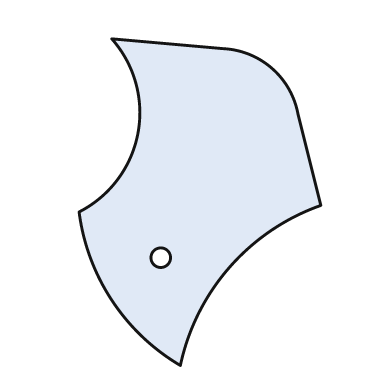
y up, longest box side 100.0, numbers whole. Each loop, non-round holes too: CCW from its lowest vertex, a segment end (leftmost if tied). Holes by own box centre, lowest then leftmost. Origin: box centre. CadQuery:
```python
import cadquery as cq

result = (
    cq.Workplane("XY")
    .moveTo(-6.0, -50.0)
    .threePointArc((9.0, -20.0), (37.0, -1.0))
    .lineTo(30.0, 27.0)
    .threePointArc((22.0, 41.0), (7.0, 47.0))
    .lineTo(-27.0, 50.0)
    .threePointArc((-19.0, 21.0), (-37.0, -3.0))
    .threePointArc((-27.0, -30.0), (-6.0, -50.0))
    .close()
    .moveTo(-12.0, -17.0)
    .circle(3.0)
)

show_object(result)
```